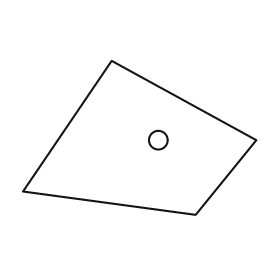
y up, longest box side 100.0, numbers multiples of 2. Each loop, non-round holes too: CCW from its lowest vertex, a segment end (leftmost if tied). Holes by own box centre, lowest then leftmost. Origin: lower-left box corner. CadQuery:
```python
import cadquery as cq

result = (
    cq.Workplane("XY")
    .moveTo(74.0, 0.0)
    .lineTo(100.0, 32.0)
    .lineTo(38.0, 66.0)
    .lineTo(0.0, 10.0)
    .close()
    .moveTo(58.0, 32.0)
    .circle(4.0)
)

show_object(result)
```